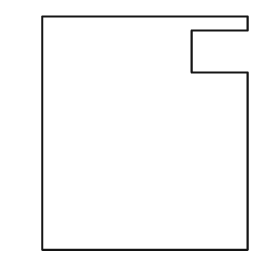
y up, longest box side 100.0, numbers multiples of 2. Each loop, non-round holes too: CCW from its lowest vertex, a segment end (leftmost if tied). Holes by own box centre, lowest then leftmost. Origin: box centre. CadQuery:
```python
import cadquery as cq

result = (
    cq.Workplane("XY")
    .moveTo(-44.0, -50.0)
    .lineTo(44.0, -50.0)
    .lineTo(44.0, 26.0)
    .lineTo(20.0, 26.0)
    .lineTo(20.0, 44.0)
    .lineTo(44.0, 44.0)
    .lineTo(44.0, 50.0)
    .lineTo(-44.0, 50.0)
    .close()
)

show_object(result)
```